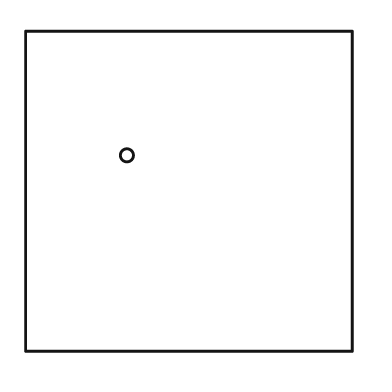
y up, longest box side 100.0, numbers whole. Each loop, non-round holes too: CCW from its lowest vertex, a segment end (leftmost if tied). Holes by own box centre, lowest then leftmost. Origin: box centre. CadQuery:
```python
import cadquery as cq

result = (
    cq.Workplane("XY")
    .moveTo(-50.0, -49.0)
    .lineTo(50.0, -49.0)
    .lineTo(50.0, 49.0)
    .lineTo(-50.0, 49.0)
    .close()
    .moveTo(-19.0, 11.0)
    .circle(2.0)
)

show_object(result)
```